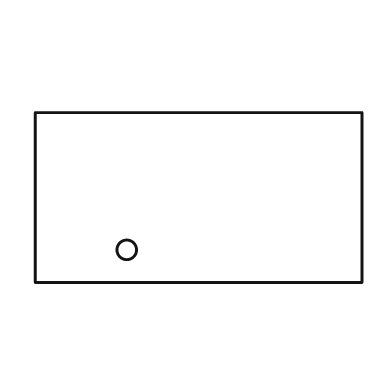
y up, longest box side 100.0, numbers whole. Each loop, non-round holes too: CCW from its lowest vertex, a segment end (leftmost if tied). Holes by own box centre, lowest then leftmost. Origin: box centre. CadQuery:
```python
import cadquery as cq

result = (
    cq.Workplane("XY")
    .moveTo(-50.0, -26.0)
    .lineTo(50.0, -26.0)
    .lineTo(50.0, 26.0)
    .lineTo(-50.0, 26.0)
    .close()
    .moveTo(-22.0, -16.0)
    .circle(3.0)
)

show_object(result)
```